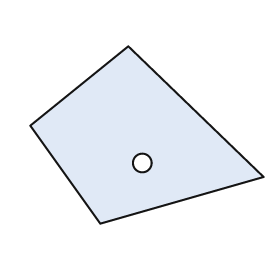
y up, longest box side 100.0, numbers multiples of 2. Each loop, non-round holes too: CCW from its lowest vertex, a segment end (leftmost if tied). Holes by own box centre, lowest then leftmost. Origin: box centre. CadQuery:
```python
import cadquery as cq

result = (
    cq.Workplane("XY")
    .moveTo(-20.0, -38.0)
    .lineTo(50.0, -18.0)
    .lineTo(-8.0, 38.0)
    .lineTo(-50.0, 4.0)
    .close()
    .moveTo(-2.0, -12.0)
    .circle(4.0)
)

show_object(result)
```